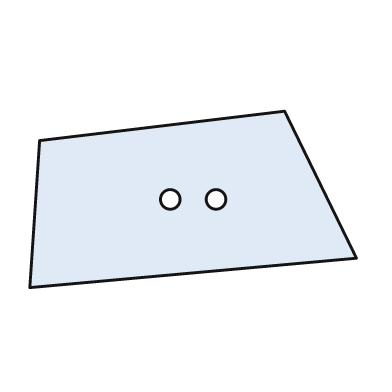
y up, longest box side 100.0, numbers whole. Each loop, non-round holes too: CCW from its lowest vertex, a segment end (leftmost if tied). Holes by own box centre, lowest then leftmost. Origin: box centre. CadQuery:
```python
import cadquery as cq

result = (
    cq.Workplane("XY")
    .moveTo(-50.0, -27.0)
    .lineTo(50.0, -18.0)
    .lineTo(28.0, 27.0)
    .lineTo(-47.0, 18.0)
    .close()
    .moveTo(-7.0, 0.0)
    .circle(3.0)
    .moveTo(7.0, 0.0)
    .circle(3.0)
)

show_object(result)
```